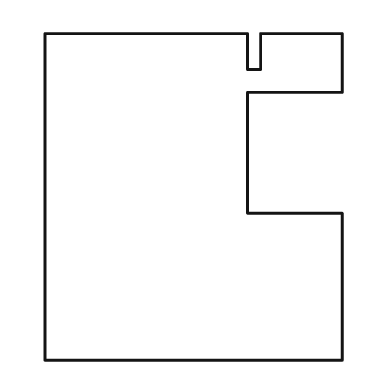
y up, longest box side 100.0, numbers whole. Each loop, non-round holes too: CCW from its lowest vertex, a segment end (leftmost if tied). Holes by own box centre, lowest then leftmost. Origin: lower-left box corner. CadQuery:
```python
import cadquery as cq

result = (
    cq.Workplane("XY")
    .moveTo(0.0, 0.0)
    .lineTo(91.0, 0.0)
    .lineTo(91.0, 45.0)
    .lineTo(62.0, 45.0)
    .lineTo(62.0, 82.0)
    .lineTo(91.0, 82.0)
    .lineTo(91.0, 100.0)
    .lineTo(66.0, 100.0)
    .lineTo(66.0, 89.0)
    .lineTo(62.0, 89.0)
    .lineTo(62.0, 100.0)
    .lineTo(0.0, 100.0)
    .close()
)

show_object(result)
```